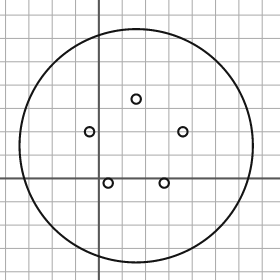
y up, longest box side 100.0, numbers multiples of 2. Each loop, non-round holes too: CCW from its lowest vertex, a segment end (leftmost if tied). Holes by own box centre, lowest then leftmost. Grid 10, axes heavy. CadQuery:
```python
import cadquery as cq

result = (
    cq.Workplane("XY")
    .moveTo(16.0, 14.0)
    .circle(50.0)
    .moveTo(4.0, -2.0)
    .circle(2.0)
    .moveTo(28.0, -2.0)
    .circle(2.0)
    .moveTo(-4.0, 20.0)
    .circle(2.0)
    .moveTo(36.0, 20.0)
    .circle(2.0)
    .moveTo(16.0, 34.0)
    .circle(2.0)
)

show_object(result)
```